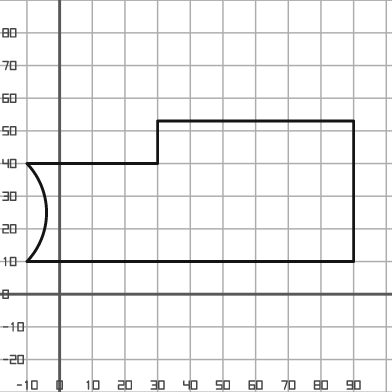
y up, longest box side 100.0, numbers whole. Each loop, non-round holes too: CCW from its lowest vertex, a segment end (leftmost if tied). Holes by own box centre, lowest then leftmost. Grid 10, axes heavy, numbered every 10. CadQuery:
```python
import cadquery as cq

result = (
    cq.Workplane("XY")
    .moveTo(-10.0, 10.0)
    .lineTo(90.0, 10.0)
    .lineTo(90.0, 53.0)
    .lineTo(30.0, 53.0)
    .lineTo(30.0, 40.0)
    .lineTo(-10.0, 40.0)
    .threePointArc((-4.0, 25.0), (-10.0, 10.0))
    .close()
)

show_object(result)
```